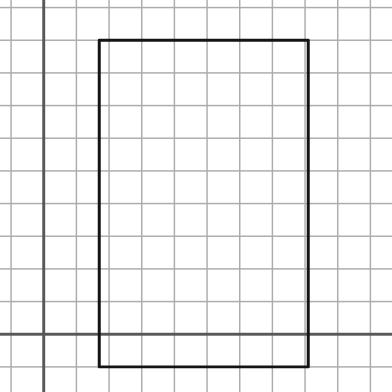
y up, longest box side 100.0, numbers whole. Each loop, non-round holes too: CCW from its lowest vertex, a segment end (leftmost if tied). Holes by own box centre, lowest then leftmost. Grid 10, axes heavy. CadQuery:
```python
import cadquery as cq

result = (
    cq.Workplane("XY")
    .moveTo(17.0, -10.0)
    .lineTo(81.0, -10.0)
    .lineTo(81.0, 90.0)
    .lineTo(17.0, 90.0)
    .close()
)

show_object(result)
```